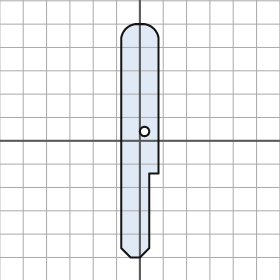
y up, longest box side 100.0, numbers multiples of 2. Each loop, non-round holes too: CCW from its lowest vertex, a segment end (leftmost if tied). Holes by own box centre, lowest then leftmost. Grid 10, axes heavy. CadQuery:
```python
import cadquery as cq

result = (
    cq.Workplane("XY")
    .moveTo(-4.0, -50.0)
    .lineTo(0.0, -50.0)
    .lineTo(4.0, -46.0)
    .lineTo(4.0, -14.0)
    .lineTo(8.0, -14.0)
    .lineTo(8.0, 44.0)
    .threePointArc((6.0, 48.0), (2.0, 50.0))
    .lineTo(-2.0, 50.0)
    .threePointArc((-6.0, 48.0), (-8.0, 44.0))
    .lineTo(-8.0, -46.0)
    .close()
    .moveTo(2.0, 4.0)
    .circle(2.0)
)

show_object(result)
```